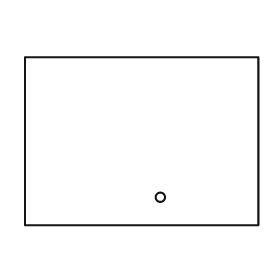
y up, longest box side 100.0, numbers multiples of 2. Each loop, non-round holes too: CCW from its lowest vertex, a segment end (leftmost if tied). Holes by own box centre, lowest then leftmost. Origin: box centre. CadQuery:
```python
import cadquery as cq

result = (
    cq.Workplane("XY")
    .moveTo(-50.0, -36.0)
    .lineTo(50.0, -36.0)
    .lineTo(50.0, 36.0)
    .lineTo(-50.0, 36.0)
    .close()
    .moveTo(8.0, -24.0)
    .circle(2.0)
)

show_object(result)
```